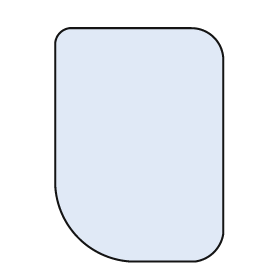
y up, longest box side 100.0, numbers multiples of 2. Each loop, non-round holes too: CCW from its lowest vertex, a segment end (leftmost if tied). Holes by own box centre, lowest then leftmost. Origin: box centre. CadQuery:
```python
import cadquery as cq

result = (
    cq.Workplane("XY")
    .moveTo(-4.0, -50.0)
    .lineTo(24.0, -50.0)
    .threePointArc((32.0, -46.0), (36.0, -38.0))
    .lineTo(36.0, 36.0)
    .threePointArc((32.0, 46.0), (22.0, 50.0))
    .lineTo(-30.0, 50.0)
    .threePointArc((-34.0, 48.0), (-36.0, 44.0))
    .lineTo(-36.0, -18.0)
    .threePointArc((-26.0, -40.0), (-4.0, -50.0))
    .close()
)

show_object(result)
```